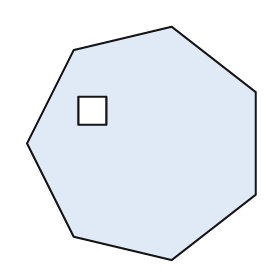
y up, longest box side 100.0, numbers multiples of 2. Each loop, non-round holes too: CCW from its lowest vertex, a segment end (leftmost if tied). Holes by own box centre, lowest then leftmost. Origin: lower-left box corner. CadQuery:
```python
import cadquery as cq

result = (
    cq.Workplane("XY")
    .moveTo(62.0, 0.0)
    .lineTo(98.0, 28.0)
    .lineTo(98.0, 72.0)
    .lineTo(62.0, 100.0)
    .lineTo(20.0, 90.0)
    .lineTo(0.0, 50.0)
    .lineTo(20.0, 10.0)
    .close()
    .moveTo(22.0, 58.0)
    .lineTo(34.0, 58.0)
    .lineTo(34.0, 70.0)
    .lineTo(22.0, 70.0)
    .close()
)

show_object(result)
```